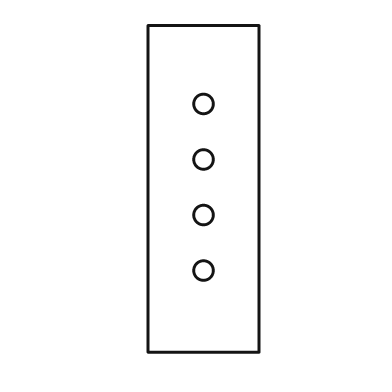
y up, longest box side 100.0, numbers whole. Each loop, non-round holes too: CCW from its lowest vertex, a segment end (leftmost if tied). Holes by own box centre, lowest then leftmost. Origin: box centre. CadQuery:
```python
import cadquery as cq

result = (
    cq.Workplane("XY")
    .moveTo(-17.0, -50.0)
    .lineTo(17.0, -50.0)
    .lineTo(17.0, 50.0)
    .lineTo(-17.0, 50.0)
    .close()
    .moveTo(0.0, -25.0)
    .circle(3.0)
    .moveTo(0.0, -8.0)
    .circle(3.0)
    .moveTo(0.0, 9.0)
    .circle(3.0)
    .moveTo(0.0, 26.0)
    .circle(3.0)
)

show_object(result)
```